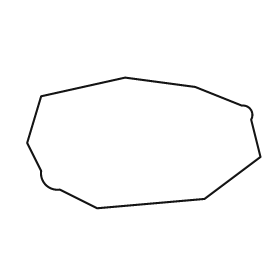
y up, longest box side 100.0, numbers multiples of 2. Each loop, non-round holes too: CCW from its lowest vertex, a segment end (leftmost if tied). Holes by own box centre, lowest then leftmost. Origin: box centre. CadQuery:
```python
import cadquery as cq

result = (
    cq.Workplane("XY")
    .moveTo(-20.0, -28.0)
    .lineTo(26.0, -24.0)
    .lineTo(50.0, -6.0)
    .lineTo(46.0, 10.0)
    .threePointArc((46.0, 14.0), (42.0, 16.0))
    .lineTo(22.0, 24.0)
    .lineTo(-8.0, 28.0)
    .lineTo(-44.0, 20.0)
    .lineTo(-50.0, 0.0)
    .lineTo(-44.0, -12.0)
    .threePointArc((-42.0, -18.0), (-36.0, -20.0))
    .close()
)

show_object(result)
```